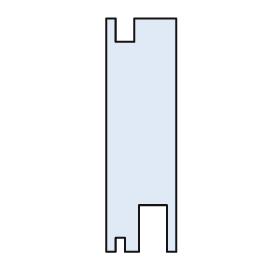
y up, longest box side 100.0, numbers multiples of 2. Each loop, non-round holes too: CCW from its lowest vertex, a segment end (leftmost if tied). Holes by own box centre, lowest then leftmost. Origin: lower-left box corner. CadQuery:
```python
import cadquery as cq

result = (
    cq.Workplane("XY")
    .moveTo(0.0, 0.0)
    .lineTo(4.0, 0.0)
    .lineTo(4.0, 6.0)
    .lineTo(8.0, 6.0)
    .lineTo(8.0, 0.0)
    .lineTo(14.0, 0.0)
    .lineTo(14.0, 20.0)
    .lineTo(26.0, 20.0)
    .lineTo(26.0, 0.0)
    .lineTo(30.0, 0.0)
    .lineTo(30.0, 100.0)
    .lineTo(12.0, 100.0)
    .lineTo(12.0, 90.0)
    .lineTo(4.0, 90.0)
    .lineTo(4.0, 100.0)
    .lineTo(0.0, 100.0)
    .close()
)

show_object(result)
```